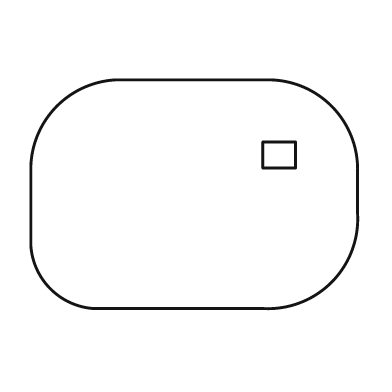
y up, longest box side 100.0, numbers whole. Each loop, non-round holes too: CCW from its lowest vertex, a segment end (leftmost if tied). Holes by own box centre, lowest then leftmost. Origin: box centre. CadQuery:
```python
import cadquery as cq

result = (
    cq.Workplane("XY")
    .moveTo(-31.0, -35.0)
    .lineTo(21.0, -35.0)
    .threePointArc((42.0, -27.0), (50.0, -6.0))
    .lineTo(50.0, 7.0)
    .threePointArc((42.0, 27.0), (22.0, 35.0))
    .lineTo(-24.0, 35.0)
    .threePointArc((-42.0, 27.0), (-50.0, 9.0))
    .lineTo(-50.0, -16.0)
    .threePointArc((-44.0, -29.0), (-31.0, -35.0))
    .close()
    .moveTo(21.0, 8.0)
    .lineTo(31.0, 8.0)
    .lineTo(31.0, 16.0)
    .lineTo(21.0, 16.0)
    .close()
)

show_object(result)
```